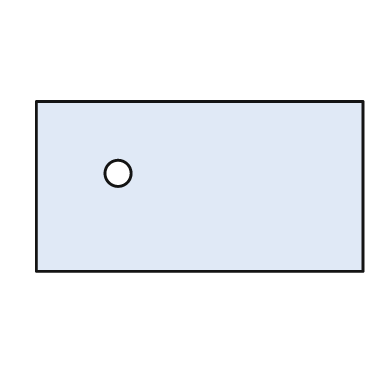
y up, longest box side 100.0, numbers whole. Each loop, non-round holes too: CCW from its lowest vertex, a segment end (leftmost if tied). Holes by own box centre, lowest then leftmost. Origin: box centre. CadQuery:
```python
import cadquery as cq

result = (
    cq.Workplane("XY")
    .moveTo(-50.0, -26.0)
    .lineTo(50.0, -26.0)
    .lineTo(50.0, 26.0)
    .lineTo(-50.0, 26.0)
    .close()
    .moveTo(-25.0, 4.0)
    .circle(4.0)
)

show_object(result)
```